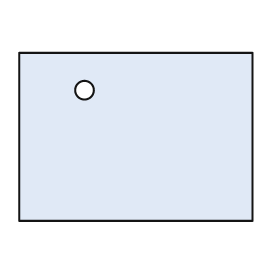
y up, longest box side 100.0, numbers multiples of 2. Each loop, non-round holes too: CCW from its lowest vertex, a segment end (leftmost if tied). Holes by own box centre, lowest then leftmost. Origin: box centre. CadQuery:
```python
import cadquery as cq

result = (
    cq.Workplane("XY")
    .moveTo(-50.0, -36.0)
    .lineTo(50.0, -36.0)
    .lineTo(50.0, 36.0)
    .lineTo(-50.0, 36.0)
    .close()
    .moveTo(-22.0, 20.0)
    .circle(4.0)
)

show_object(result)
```